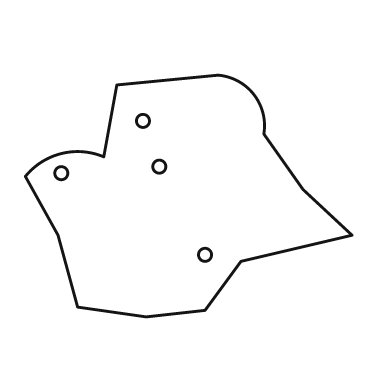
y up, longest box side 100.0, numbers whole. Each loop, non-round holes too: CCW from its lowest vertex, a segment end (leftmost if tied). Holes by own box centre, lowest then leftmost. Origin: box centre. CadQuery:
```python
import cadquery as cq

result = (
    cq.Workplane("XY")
    .moveTo(-13.0, -37.0)
    .lineTo(5.0, -35.0)
    .lineTo(16.0, -20.0)
    .lineTo(50.0, -12.0)
    .lineTo(35.0, 2.0)
    .lineTo(23.0, 19.0)
    .threePointArc((20.0, 31.0), (9.0, 37.0))
    .lineTo(-22.0, 34.0)
    .lineTo(-26.0, 12.0)
    .threePointArc((-39.0, 13.0), (-50.0, 6.0))
    .lineTo(-40.0, -12.0)
    .lineTo(-34.0, -34.0)
    .close()
    .moveTo(5.0, -18.0)
    .circle(2.0)
    .moveTo(-39.0, 7.0)
    .circle(2.0)
    .moveTo(-9.0, 9.0)
    .circle(2.0)
    .moveTo(-14.0, 23.0)
    .circle(2.0)
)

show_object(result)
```